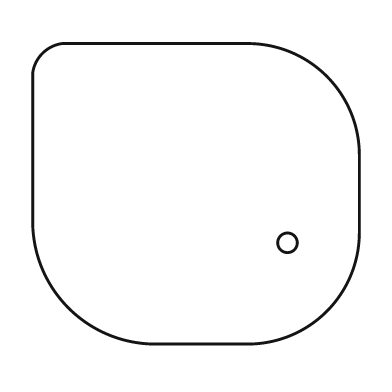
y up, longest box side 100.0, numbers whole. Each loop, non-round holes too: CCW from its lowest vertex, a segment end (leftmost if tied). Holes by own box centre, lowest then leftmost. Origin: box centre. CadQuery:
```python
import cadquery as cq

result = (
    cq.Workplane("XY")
    .moveTo(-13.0, -46.0)
    .lineTo(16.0, -46.0)
    .threePointArc((40.0, -36.0), (50.0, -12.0))
    .lineTo(50.0, 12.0)
    .threePointArc((40.0, 36.0), (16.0, 46.0))
    .lineTo(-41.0, 46.0)
    .threePointArc((-47.0, 43.0), (-50.0, 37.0))
    .lineTo(-50.0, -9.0)
    .threePointArc((-39.0, -35.0), (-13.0, -46.0))
    .close()
    .moveTo(28.0, -15.0)
    .circle(3.0)
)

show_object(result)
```